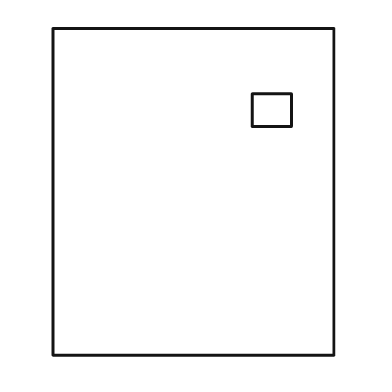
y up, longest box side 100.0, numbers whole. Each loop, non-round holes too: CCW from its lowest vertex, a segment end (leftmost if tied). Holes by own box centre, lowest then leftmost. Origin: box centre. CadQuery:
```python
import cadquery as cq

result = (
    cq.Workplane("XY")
    .moveTo(-43.0, -50.0)
    .lineTo(43.0, -50.0)
    .lineTo(43.0, 50.0)
    .lineTo(-43.0, 50.0)
    .close()
    .moveTo(18.0, 20.0)
    .lineTo(30.0, 20.0)
    .lineTo(30.0, 30.0)
    .lineTo(18.0, 30.0)
    .close()
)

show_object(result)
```